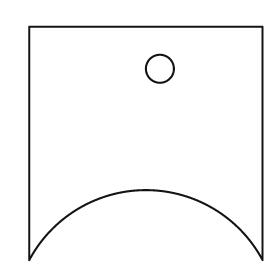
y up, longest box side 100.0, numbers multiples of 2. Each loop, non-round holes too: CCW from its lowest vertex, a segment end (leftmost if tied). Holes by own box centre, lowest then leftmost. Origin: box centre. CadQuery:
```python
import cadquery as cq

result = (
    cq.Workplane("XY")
    .moveTo(-50.0, -50.0)
    .threePointArc((0.0, -20.0), (50.0, -50.0))
    .lineTo(50.0, 50.0)
    .lineTo(-50.0, 50.0)
    .close()
    .moveTo(6.0, 32.0)
    .circle(6.0)
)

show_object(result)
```